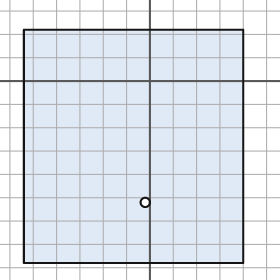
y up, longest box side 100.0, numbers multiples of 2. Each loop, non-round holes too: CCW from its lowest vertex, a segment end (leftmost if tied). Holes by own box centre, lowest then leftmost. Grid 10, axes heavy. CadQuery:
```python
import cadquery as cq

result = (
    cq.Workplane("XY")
    .moveTo(-54.0, -78.0)
    .lineTo(40.0, -78.0)
    .lineTo(40.0, 22.0)
    .lineTo(-54.0, 22.0)
    .close()
    .moveTo(-2.0, -52.0)
    .circle(2.0)
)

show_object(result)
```